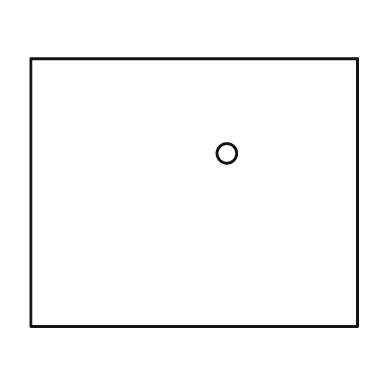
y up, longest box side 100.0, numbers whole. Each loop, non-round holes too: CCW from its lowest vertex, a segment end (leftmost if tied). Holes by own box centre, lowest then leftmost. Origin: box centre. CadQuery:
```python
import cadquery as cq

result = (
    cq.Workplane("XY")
    .moveTo(-50.0, -41.0)
    .lineTo(50.0, -41.0)
    .lineTo(50.0, 41.0)
    .lineTo(-50.0, 41.0)
    .close()
    .moveTo(10.0, 12.0)
    .circle(3.0)
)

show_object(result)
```